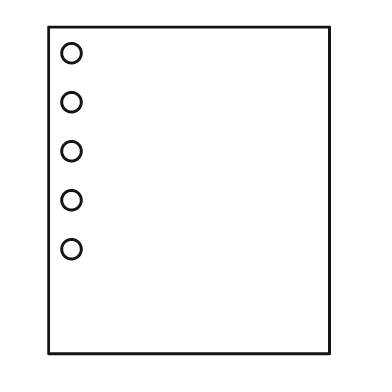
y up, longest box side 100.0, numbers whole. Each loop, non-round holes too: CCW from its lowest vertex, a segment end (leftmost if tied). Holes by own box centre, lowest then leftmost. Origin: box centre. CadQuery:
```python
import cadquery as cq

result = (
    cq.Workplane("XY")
    .moveTo(-43.0, -50.0)
    .lineTo(43.0, -50.0)
    .lineTo(43.0, 50.0)
    .lineTo(-43.0, 50.0)
    .close()
    .moveTo(-36.0, -18.0)
    .circle(3.0)
    .moveTo(-36.0, -3.0)
    .circle(3.0)
    .moveTo(-36.0, 12.0)
    .circle(3.0)
    .moveTo(-36.0, 27.0)
    .circle(3.0)
    .moveTo(-36.0, 42.0)
    .circle(3.0)
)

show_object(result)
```